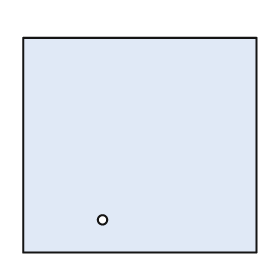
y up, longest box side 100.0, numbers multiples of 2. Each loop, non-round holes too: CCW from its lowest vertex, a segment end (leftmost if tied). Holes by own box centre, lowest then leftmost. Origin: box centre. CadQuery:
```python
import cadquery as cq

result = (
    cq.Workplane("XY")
    .moveTo(-50.0, -46.0)
    .lineTo(50.0, -46.0)
    .lineTo(50.0, 46.0)
    .lineTo(-50.0, 46.0)
    .close()
    .moveTo(-16.0, -32.0)
    .circle(2.0)
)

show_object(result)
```